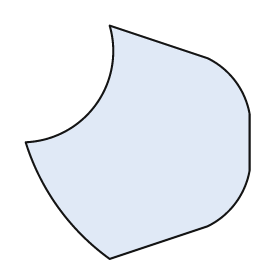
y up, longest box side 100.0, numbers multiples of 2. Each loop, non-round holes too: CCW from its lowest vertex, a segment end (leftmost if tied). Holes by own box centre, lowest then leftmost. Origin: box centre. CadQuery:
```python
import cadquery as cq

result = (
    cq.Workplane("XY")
    .moveTo(-12.0, -50.0)
    .lineTo(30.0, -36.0)
    .threePointArc((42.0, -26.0), (48.0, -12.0))
    .lineTo(48.0, 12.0)
    .threePointArc((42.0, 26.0), (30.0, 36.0))
    .lineTo(-12.0, 50.0)
    .threePointArc((-18.0, 16.0), (-48.0, 0.0))
    .threePointArc((-34.0, -28.0), (-12.0, -50.0))
    .close()
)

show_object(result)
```